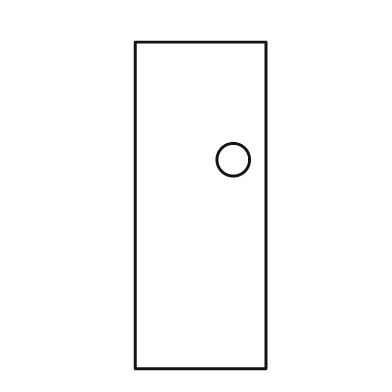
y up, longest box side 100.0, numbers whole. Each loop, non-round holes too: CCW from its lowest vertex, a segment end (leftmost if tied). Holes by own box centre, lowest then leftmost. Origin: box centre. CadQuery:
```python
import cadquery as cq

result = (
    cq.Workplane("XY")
    .moveTo(-20.0, -50.0)
    .lineTo(20.0, -50.0)
    .lineTo(20.0, 50.0)
    .lineTo(-20.0, 50.0)
    .close()
    .moveTo(10.0, 14.0)
    .circle(5.0)
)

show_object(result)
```